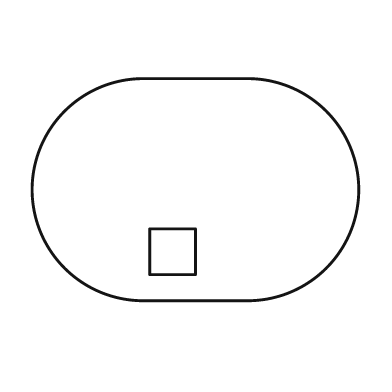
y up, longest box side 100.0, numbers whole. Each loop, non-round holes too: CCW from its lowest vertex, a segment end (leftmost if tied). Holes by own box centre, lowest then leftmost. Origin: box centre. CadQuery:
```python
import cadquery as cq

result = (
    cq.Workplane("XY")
    .moveTo(-16.0, -34.0)
    .lineTo(16.0, -34.0)
    .threePointArc((50.0, 0.0), (16.0, 34.0))
    .lineTo(-16.0, 34.0)
    .threePointArc((-50.0, 0.0), (-16.0, -34.0))
    .close()
    .moveTo(-14.0, -26.0)
    .lineTo(0.0, -26.0)
    .lineTo(0.0, -12.0)
    .lineTo(-14.0, -12.0)
    .close()
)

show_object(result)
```